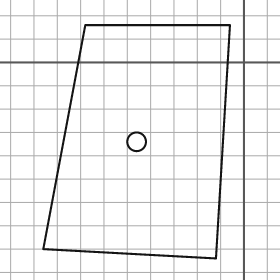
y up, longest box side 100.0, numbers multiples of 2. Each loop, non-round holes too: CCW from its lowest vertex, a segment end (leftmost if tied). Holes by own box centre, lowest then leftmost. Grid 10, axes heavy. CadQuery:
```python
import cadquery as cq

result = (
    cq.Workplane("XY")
    .moveTo(-12.0, -84.0)
    .lineTo(-6.0, 16.0)
    .lineTo(-68.0, 16.0)
    .lineTo(-86.0, -80.0)
    .close()
    .moveTo(-46.0, -34.0)
    .circle(4.0)
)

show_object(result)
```